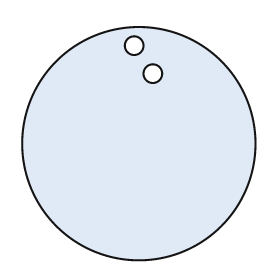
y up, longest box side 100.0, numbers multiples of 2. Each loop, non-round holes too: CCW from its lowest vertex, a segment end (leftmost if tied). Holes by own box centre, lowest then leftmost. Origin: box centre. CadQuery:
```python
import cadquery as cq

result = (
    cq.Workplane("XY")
    .moveTo(0.0, 0.0)
    .circle(50.0)
    .moveTo(6.0, 30.0)
    .circle(4.0)
    .moveTo(-2.0, 42.0)
    .circle(4.0)
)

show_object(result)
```